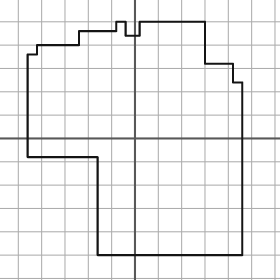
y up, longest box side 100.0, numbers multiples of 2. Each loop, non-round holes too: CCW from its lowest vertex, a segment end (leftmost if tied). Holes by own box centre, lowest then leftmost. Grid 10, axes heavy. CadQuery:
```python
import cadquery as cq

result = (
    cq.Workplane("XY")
    .moveTo(-16.0, -50.0)
    .lineTo(46.0, -50.0)
    .lineTo(46.0, 24.0)
    .lineTo(42.0, 24.0)
    .lineTo(42.0, 32.0)
    .lineTo(30.0, 32.0)
    .lineTo(30.0, 50.0)
    .lineTo(2.0, 50.0)
    .lineTo(2.0, 44.0)
    .lineTo(-4.0, 44.0)
    .lineTo(-4.0, 50.0)
    .lineTo(-8.0, 50.0)
    .lineTo(-8.0, 46.0)
    .lineTo(-24.0, 46.0)
    .lineTo(-24.0, 40.0)
    .lineTo(-42.0, 40.0)
    .lineTo(-42.0, 36.0)
    .lineTo(-46.0, 36.0)
    .lineTo(-46.0, -8.0)
    .lineTo(-16.0, -8.0)
    .close()
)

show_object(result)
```